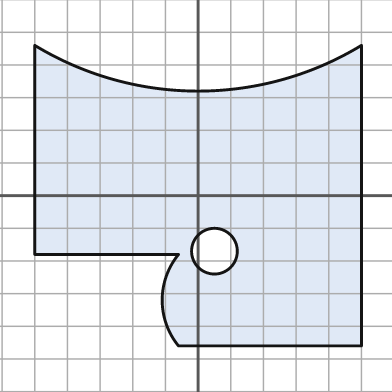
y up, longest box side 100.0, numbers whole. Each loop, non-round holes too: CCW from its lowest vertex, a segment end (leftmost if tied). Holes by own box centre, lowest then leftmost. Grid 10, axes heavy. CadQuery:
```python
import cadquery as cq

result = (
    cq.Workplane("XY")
    .moveTo(-6.0, -46.0)
    .lineTo(50.0, -46.0)
    .lineTo(50.0, 46.0)
    .threePointArc((0.0, 32.0), (-50.0, 46.0))
    .lineTo(-50.0, -18.0)
    .lineTo(-6.0, -18.0)
    .threePointArc((-11.0, -32.0), (-6.0, -46.0))
    .close()
    .moveTo(5.0, -17.0)
    .circle(7.0)
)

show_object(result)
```